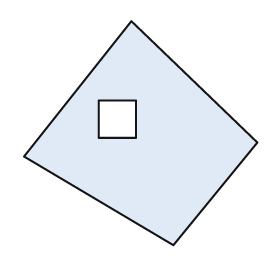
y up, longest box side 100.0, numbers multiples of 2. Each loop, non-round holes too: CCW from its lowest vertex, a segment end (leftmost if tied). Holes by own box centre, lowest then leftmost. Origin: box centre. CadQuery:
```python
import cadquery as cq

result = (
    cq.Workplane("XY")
    .moveTo(14.0, -48.0)
    .lineTo(50.0, -4.0)
    .lineTo(-4.0, 48.0)
    .lineTo(-50.0, -10.0)
    .close()
    .moveTo(-18.0, -2.0)
    .lineTo(-2.0, -2.0)
    .lineTo(-2.0, 14.0)
    .lineTo(-18.0, 14.0)
    .close()
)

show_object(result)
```